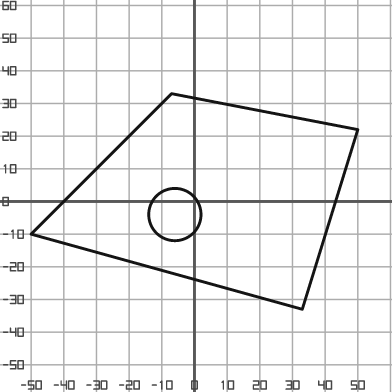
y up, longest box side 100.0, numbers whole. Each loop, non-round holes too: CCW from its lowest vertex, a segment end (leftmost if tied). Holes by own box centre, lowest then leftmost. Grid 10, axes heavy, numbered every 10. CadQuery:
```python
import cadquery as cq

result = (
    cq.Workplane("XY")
    .moveTo(33.0, -33.0)
    .lineTo(50.0, 22.0)
    .lineTo(-7.0, 33.0)
    .lineTo(-50.0, -10.0)
    .close()
    .moveTo(-6.0, -4.0)
    .circle(8.0)
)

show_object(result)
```